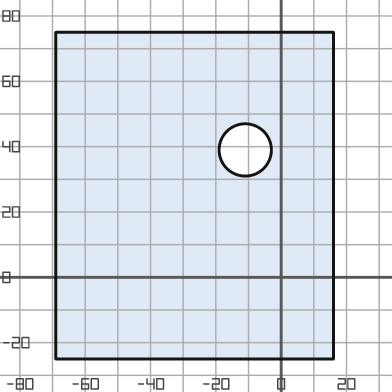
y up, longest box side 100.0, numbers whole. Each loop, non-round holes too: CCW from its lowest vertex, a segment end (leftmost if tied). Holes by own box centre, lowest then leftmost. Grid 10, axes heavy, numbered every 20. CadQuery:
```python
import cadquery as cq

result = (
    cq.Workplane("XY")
    .moveTo(-69.0, -25.0)
    .lineTo(16.0, -25.0)
    .lineTo(16.0, 75.0)
    .lineTo(-69.0, 75.0)
    .close()
    .moveTo(-11.0, 39.0)
    .circle(8.0)
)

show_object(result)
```